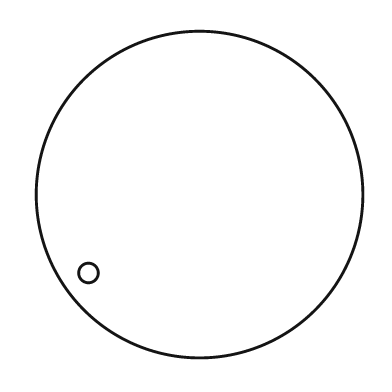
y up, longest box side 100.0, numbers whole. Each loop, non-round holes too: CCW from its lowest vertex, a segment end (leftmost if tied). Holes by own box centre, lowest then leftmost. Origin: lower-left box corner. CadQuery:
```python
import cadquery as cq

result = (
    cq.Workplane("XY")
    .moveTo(50.0, 50.0)
    .circle(50.0)
    .moveTo(16.0, 26.0)
    .circle(3.0)
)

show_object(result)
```